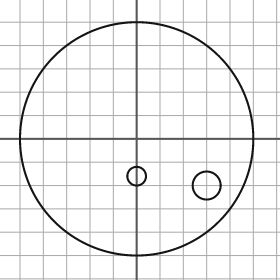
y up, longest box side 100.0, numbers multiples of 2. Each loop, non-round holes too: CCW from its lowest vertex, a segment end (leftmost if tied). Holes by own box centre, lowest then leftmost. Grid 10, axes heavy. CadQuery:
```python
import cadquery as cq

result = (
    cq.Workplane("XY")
    .moveTo(0.0, 0.0)
    .circle(50.0)
    .moveTo(30.0, -20.0)
    .circle(6.0)
    .moveTo(0.0, -16.0)
    .circle(4.0)
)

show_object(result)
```